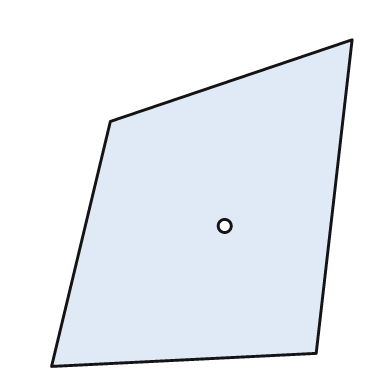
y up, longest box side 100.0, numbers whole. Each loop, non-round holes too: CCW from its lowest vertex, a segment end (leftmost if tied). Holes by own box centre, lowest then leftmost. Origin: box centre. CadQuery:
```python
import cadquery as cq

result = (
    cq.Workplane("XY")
    .moveTo(-46.0, -50.0)
    .lineTo(35.0, -46.0)
    .lineTo(46.0, 50.0)
    .lineTo(-28.0, 25.0)
    .close()
    .moveTo(7.0, -7.0)
    .circle(2.0)
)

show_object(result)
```